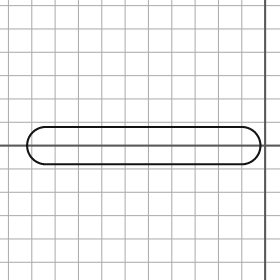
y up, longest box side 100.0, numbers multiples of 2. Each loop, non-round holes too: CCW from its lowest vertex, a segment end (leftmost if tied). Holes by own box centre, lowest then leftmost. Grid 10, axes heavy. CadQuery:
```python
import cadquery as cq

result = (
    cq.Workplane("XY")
    .moveTo(-94.0, -8.0)
    .lineTo(-10.0, -8.0)
    .threePointArc((-2.0, 0.0), (-10.0, 8.0))
    .lineTo(-94.0, 8.0)
    .threePointArc((-102.0, 0.0), (-94.0, -8.0))
    .close()
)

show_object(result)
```